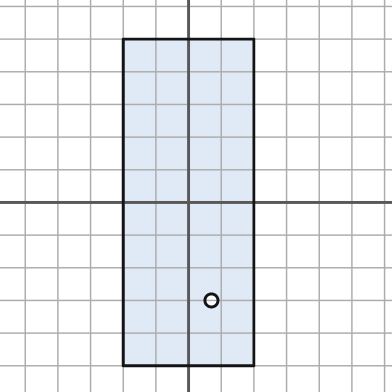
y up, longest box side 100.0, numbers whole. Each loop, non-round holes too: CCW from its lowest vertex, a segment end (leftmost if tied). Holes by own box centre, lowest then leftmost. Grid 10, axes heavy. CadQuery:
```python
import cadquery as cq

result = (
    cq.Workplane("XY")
    .moveTo(-20.0, -50.0)
    .lineTo(20.0, -50.0)
    .lineTo(20.0, 50.0)
    .lineTo(-20.0, 50.0)
    .close()
    .moveTo(7.0, -30.0)
    .circle(2.0)
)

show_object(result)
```